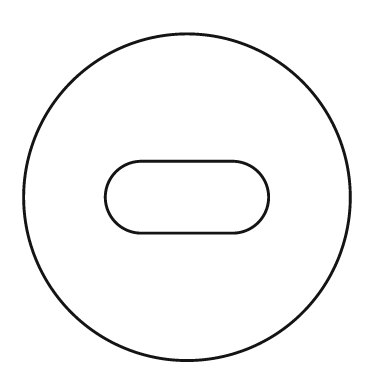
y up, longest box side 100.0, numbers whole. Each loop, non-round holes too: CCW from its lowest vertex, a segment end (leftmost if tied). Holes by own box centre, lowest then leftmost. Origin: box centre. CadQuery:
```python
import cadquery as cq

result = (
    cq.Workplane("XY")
    .moveTo(0.0, 0.0)
    .circle(50.0)
    .moveTo(-14.0, -11.0)
    .lineTo(14.0, -11.0)
    .threePointArc((25.0, 0.0), (14.0, 11.0))
    .lineTo(-14.0, 11.0)
    .threePointArc((-25.0, 0.0), (-14.0, -11.0))
    .close()
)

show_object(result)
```